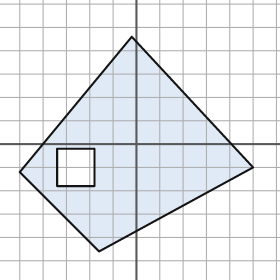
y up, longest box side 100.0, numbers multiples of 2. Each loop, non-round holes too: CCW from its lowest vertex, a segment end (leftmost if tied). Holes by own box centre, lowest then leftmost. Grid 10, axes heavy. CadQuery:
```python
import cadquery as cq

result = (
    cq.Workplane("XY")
    .moveTo(-16.0, -46.0)
    .lineTo(50.0, -10.0)
    .lineTo(-2.0, 46.0)
    .lineTo(-50.0, -12.0)
    .close()
    .moveTo(-34.0, -18.0)
    .lineTo(-18.0, -18.0)
    .lineTo(-18.0, -2.0)
    .lineTo(-34.0, -2.0)
    .close()
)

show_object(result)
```